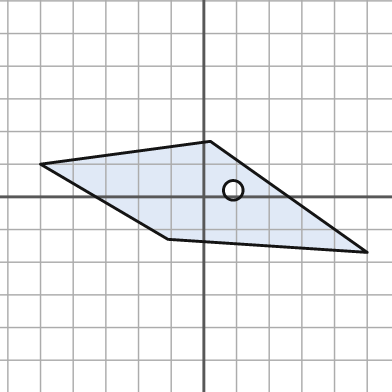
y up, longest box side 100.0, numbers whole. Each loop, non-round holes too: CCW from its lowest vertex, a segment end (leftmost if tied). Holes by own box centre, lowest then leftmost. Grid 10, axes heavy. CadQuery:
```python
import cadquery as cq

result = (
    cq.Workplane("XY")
    .moveTo(50.0, -17.0)
    .lineTo(2.0, 17.0)
    .lineTo(-50.0, 10.0)
    .lineTo(-11.0, -13.0)
    .close()
    .moveTo(9.0, 2.0)
    .circle(3.0)
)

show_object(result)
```